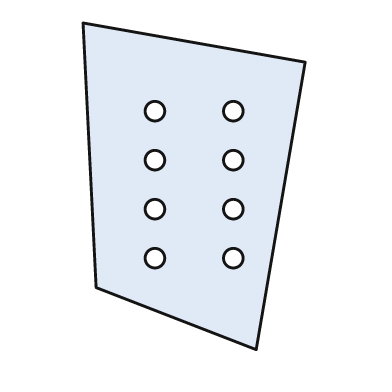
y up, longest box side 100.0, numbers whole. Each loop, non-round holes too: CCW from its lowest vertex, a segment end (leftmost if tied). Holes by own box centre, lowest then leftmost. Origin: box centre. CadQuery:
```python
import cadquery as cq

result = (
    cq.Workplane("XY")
    .moveTo(19.0, -50.0)
    .lineTo(34.0, 38.0)
    .lineTo(-34.0, 50.0)
    .lineTo(-30.0, -31.0)
    .close()
    .moveTo(-12.0, -22.0)
    .circle(3.0)
    .moveTo(12.0, -22.0)
    .circle(3.0)
    .moveTo(-12.0, -7.0)
    .circle(3.0)
    .moveTo(12.0, -7.0)
    .circle(3.0)
    .moveTo(-12.0, 8.0)
    .circle(3.0)
    .moveTo(12.0, 8.0)
    .circle(3.0)
    .moveTo(-12.0, 23.0)
    .circle(3.0)
    .moveTo(12.0, 23.0)
    .circle(3.0)
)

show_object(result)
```